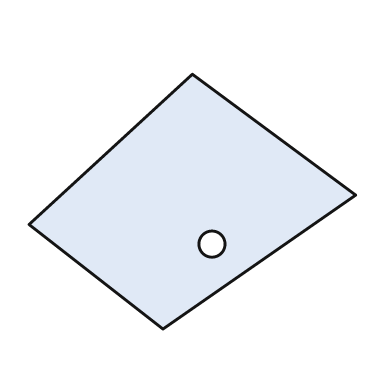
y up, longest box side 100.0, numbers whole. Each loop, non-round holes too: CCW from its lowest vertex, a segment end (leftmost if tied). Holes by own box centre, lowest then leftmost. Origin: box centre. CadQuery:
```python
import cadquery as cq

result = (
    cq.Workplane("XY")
    .moveTo(-9.0, -39.0)
    .lineTo(50.0, 2.0)
    .lineTo(0.0, 39.0)
    .lineTo(-50.0, -7.0)
    .close()
    .moveTo(6.0, -13.0)
    .circle(4.0)
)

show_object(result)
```